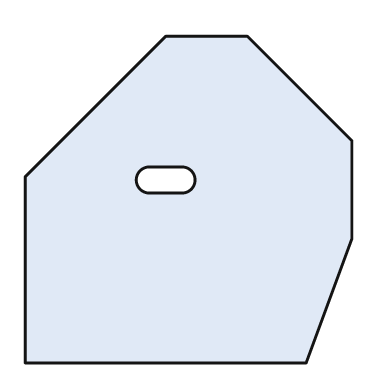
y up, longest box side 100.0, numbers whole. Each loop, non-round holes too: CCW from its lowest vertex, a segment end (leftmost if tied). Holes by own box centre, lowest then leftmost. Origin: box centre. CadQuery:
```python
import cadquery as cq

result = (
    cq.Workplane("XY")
    .moveTo(-50.0, -50.0)
    .lineTo(36.0, -50.0)
    .lineTo(50.0, -12.0)
    .lineTo(50.0, 18.0)
    .lineTo(18.0, 50.0)
    .lineTo(-7.0, 50.0)
    .lineTo(-50.0, 7.0)
    .close()
    .moveTo(-12.0, 2.0)
    .lineTo(-2.0, 2.0)
    .threePointArc((2.0, 6.0), (-2.0, 10.0))
    .lineTo(-12.0, 10.0)
    .threePointArc((-16.0, 6.0), (-12.0, 2.0))
    .close()
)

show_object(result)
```